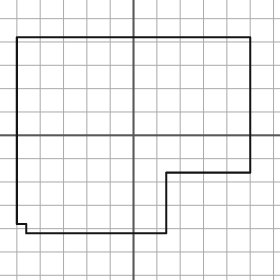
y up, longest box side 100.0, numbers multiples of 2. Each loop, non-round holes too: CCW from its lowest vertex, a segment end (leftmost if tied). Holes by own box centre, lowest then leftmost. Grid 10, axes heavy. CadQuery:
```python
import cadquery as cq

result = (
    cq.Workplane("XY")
    .moveTo(-46.0, -42.0)
    .lineTo(14.0, -42.0)
    .lineTo(14.0, -16.0)
    .lineTo(50.0, -16.0)
    .lineTo(50.0, 42.0)
    .lineTo(-50.0, 42.0)
    .lineTo(-50.0, -38.0)
    .lineTo(-46.0, -38.0)
    .close()
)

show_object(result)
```